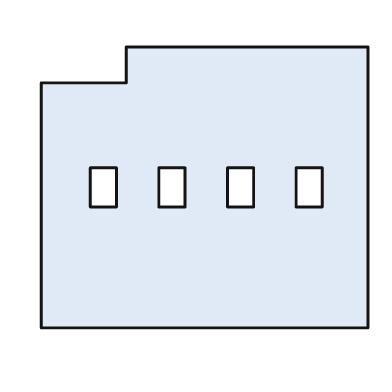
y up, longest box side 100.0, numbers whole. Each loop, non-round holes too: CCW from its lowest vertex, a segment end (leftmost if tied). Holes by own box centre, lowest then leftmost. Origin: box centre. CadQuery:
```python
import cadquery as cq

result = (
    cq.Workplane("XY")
    .moveTo(-50.0, -43.0)
    .lineTo(50.0, -43.0)
    .lineTo(50.0, 43.0)
    .lineTo(-24.0, 43.0)
    .lineTo(-24.0, 32.0)
    .lineTo(-50.0, 32.0)
    .close()
    .moveTo(-35.0, -6.0)
    .lineTo(-27.0, -6.0)
    .lineTo(-27.0, 6.0)
    .lineTo(-35.0, 6.0)
    .close()
    .moveTo(-14.0, -6.0)
    .lineTo(-6.0, -6.0)
    .lineTo(-6.0, 6.0)
    .lineTo(-14.0, 6.0)
    .close()
    .moveTo(7.0, -6.0)
    .lineTo(15.0, -6.0)
    .lineTo(15.0, 6.0)
    .lineTo(7.0, 6.0)
    .close()
    .moveTo(28.0, -6.0)
    .lineTo(36.0, -6.0)
    .lineTo(36.0, 6.0)
    .lineTo(28.0, 6.0)
    .close()
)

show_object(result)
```